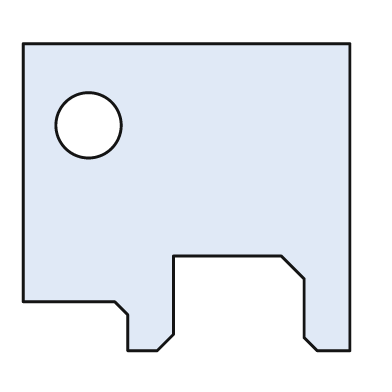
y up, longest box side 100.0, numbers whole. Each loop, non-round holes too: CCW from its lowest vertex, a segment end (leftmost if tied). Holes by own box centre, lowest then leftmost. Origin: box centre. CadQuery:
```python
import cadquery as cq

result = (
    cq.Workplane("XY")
    .moveTo(-18.0, -47.0)
    .lineTo(-9.0, -47.0)
    .lineTo(-4.0, -42.0)
    .lineTo(-4.0, -18.0)
    .lineTo(29.0, -18.0)
    .lineTo(36.0, -25.0)
    .lineTo(36.0, -43.0)
    .lineTo(40.0, -47.0)
    .lineTo(50.0, -47.0)
    .lineTo(50.0, 47.0)
    .lineTo(-50.0, 47.0)
    .lineTo(-50.0, -32.0)
    .lineTo(-22.0, -32.0)
    .lineTo(-18.0, -36.0)
    .close()
    .moveTo(-30.0, 22.0)
    .circle(10.0)
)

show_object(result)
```